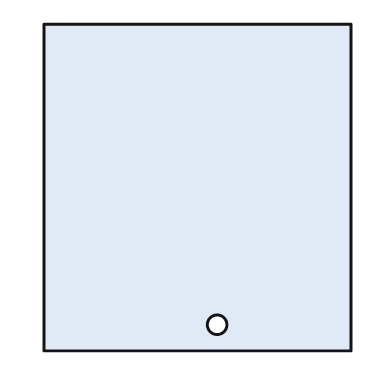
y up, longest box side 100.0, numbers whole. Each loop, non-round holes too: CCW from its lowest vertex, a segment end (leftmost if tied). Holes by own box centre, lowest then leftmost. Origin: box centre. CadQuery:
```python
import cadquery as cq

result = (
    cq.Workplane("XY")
    .moveTo(-47.0, -50.0)
    .lineTo(47.0, -50.0)
    .lineTo(47.0, 50.0)
    .lineTo(-47.0, 50.0)
    .close()
    .moveTo(6.0, -42.0)
    .circle(3.0)
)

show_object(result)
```